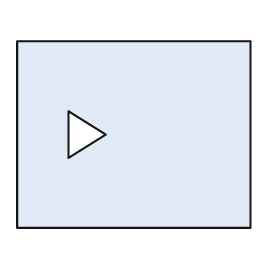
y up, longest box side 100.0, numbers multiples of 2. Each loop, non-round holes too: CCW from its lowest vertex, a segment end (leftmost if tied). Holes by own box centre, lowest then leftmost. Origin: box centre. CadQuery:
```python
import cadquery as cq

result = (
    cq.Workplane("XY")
    .moveTo(-50.0, -40.0)
    .lineTo(50.0, -40.0)
    .lineTo(50.0, 40.0)
    .lineTo(-50.0, 40.0)
    .close()
    .moveTo(-28.0, -10.0)
    .lineTo(-12.0, 0.0)
    .lineTo(-28.0, 10.0)
    .close()
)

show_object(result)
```